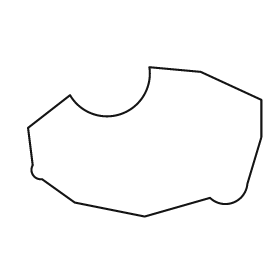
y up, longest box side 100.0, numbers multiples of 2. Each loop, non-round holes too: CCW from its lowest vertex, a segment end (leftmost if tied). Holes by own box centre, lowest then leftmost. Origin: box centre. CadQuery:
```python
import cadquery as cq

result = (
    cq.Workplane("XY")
    .moveTo(0.0, -32.0)
    .lineTo(28.0, -24.0)
    .threePointArc((38.0, -26.0), (44.0, -18.0))
    .lineTo(50.0, 2.0)
    .lineTo(50.0, 18.0)
    .lineTo(24.0, 30.0)
    .lineTo(2.0, 32.0)
    .threePointArc((-10.0, 12.0), (-32.0, 20.0))
    .lineTo(-50.0, 6.0)
    .lineTo(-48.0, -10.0)
    .threePointArc((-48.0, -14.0), (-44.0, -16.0))
    .lineTo(-30.0, -26.0)
    .close()
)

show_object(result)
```